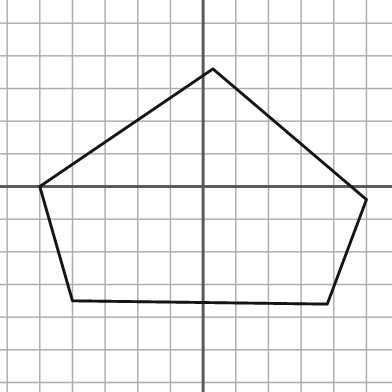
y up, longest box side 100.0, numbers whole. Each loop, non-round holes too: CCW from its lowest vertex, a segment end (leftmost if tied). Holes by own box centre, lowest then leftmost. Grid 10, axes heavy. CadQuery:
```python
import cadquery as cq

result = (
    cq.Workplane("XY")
    .moveTo(38.0, -36.0)
    .lineTo(50.0, -4.0)
    .lineTo(3.0, 36.0)
    .lineTo(-50.0, 0.0)
    .lineTo(-40.0, -35.0)
    .close()
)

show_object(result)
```